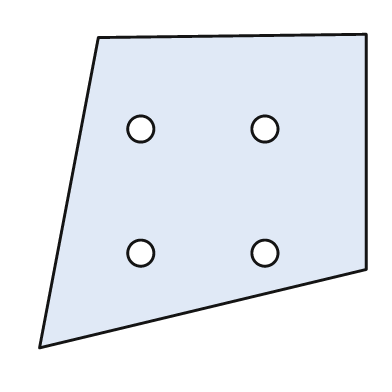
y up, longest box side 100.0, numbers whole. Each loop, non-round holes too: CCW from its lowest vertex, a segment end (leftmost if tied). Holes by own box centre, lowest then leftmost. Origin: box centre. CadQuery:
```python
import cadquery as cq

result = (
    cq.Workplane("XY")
    .moveTo(-50.0, -48.0)
    .lineTo(50.0, -24.0)
    .lineTo(50.0, 48.0)
    .lineTo(-32.0, 47.0)
    .close()
    .moveTo(-19.0, -19.0)
    .circle(4.0)
    .moveTo(19.0, -19.0)
    .circle(4.0)
    .moveTo(-19.0, 19.0)
    .circle(4.0)
    .moveTo(19.0, 19.0)
    .circle(4.0)
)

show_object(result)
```